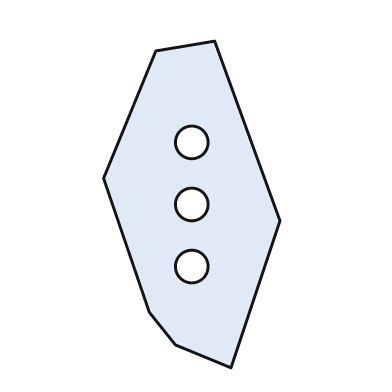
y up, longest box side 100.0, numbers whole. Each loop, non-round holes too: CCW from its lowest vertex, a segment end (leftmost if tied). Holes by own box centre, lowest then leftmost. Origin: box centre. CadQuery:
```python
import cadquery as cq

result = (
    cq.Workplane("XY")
    .moveTo(12.0, -50.0)
    .lineTo(27.0, -5.0)
    .lineTo(7.0, 50.0)
    .lineTo(-11.0, 47.0)
    .lineTo(-27.0, 8.0)
    .lineTo(-13.0, -33.0)
    .lineTo(-5.0, -43.0)
    .close()
    .moveTo(0.0, -19.0)
    .circle(5.0)
    .moveTo(0.0, 0.0)
    .circle(5.0)
    .moveTo(0.0, 19.0)
    .circle(5.0)
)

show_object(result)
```